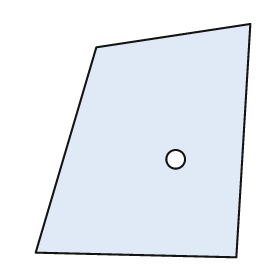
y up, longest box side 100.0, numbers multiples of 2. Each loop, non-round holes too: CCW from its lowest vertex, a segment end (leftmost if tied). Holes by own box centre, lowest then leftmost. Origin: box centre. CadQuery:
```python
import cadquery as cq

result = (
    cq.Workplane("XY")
    .moveTo(40.0, -50.0)
    .lineTo(46.0, 50.0)
    .lineTo(-20.0, 40.0)
    .lineTo(-46.0, -48.0)
    .close()
    .moveTo(14.0, -8.0)
    .circle(4.0)
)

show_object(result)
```